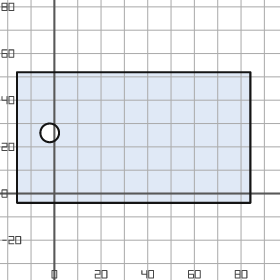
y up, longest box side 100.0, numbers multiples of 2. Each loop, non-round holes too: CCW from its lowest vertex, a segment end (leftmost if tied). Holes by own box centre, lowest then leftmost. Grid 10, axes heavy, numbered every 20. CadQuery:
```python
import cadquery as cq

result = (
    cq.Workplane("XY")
    .moveTo(-16.0, -4.0)
    .lineTo(84.0, -4.0)
    .lineTo(84.0, 52.0)
    .lineTo(-16.0, 52.0)
    .close()
    .moveTo(-2.0, 26.0)
    .circle(4.0)
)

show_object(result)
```